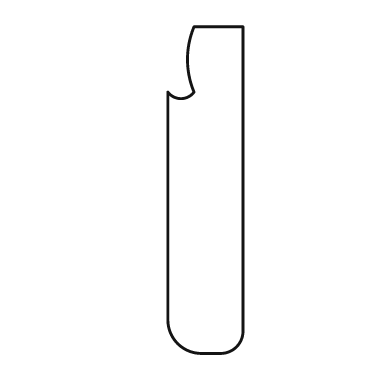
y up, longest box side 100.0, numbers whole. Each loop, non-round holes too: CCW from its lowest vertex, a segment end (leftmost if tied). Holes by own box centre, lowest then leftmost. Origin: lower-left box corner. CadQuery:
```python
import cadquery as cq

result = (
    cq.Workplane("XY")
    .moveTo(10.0, 0.0)
    .lineTo(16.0, 0.0)
    .threePointArc((21.0, 2.0), (23.0, 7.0))
    .lineTo(23.0, 100.0)
    .lineTo(8.0, 100.0)
    .threePointArc((6.0, 90.0), (8.0, 80.0))
    .threePointArc((4.0, 78.0), (0.0, 80.0))
    .lineTo(0.0, 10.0)
    .threePointArc((3.0, 3.0), (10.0, 0.0))
    .close()
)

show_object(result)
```